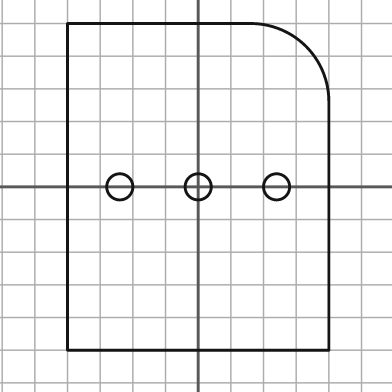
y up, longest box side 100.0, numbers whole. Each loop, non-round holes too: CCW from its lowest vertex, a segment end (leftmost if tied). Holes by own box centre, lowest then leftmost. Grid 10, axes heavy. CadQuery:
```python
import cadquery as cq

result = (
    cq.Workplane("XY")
    .moveTo(-40.0, -50.0)
    .lineTo(40.0, -50.0)
    .lineTo(40.0, 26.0)
    .threePointArc((33.0, 43.0), (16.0, 50.0))
    .lineTo(-40.0, 50.0)
    .close()
    .moveTo(-24.0, 0.0)
    .circle(4.0)
    .moveTo(0.0, 0.0)
    .circle(4.0)
    .moveTo(24.0, 0.0)
    .circle(4.0)
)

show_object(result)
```